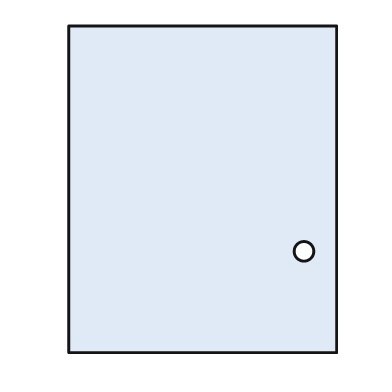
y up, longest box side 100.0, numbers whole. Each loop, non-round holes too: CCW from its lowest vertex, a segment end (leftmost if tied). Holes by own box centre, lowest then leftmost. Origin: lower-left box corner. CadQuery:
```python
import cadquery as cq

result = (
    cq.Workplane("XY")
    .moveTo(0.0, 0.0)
    .lineTo(82.0, 0.0)
    .lineTo(82.0, 100.0)
    .lineTo(0.0, 100.0)
    .close()
    .moveTo(72.0, 31.0)
    .circle(3.0)
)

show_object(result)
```